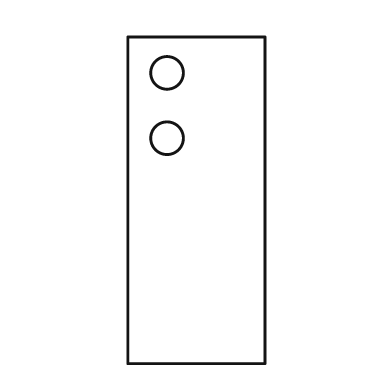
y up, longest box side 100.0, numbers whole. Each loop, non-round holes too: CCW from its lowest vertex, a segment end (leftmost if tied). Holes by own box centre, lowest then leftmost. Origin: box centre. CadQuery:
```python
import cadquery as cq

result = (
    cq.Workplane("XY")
    .moveTo(-21.0, -50.0)
    .lineTo(21.0, -50.0)
    .lineTo(21.0, 50.0)
    .lineTo(-21.0, 50.0)
    .close()
    .moveTo(-9.0, 19.0)
    .circle(5.0)
    .moveTo(-9.0, 39.0)
    .circle(5.0)
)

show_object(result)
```